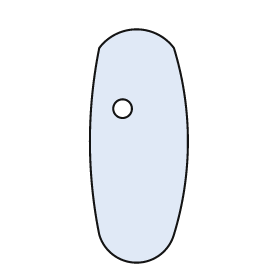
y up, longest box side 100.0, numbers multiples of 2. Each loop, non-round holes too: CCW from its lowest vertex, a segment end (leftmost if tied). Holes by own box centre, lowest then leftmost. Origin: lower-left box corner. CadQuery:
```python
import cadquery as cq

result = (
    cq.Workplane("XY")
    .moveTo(4.0, 12.0)
    .threePointArc((20.0, 0.0), (36.0, 12.0))
    .threePointArc((42.0, 52.0), (36.0, 92.0))
    .threePointArc((20.0, 100.0), (4.0, 92.0))
    .threePointArc((0.0, 52.0), (4.0, 12.0))
    .close()
    .moveTo(14.0, 66.0)
    .circle(4.0)
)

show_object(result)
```